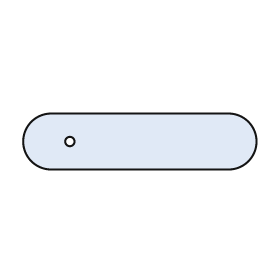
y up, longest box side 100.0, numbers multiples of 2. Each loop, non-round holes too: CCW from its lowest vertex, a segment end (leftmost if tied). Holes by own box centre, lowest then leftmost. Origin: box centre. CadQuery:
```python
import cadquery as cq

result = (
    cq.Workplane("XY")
    .moveTo(-38.0, -12.0)
    .lineTo(38.0, -12.0)
    .threePointArc((50.0, 0.0), (38.0, 12.0))
    .lineTo(-38.0, 12.0)
    .threePointArc((-50.0, 0.0), (-38.0, -12.0))
    .close()
    .moveTo(-30.0, 0.0)
    .circle(2.0)
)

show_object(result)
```